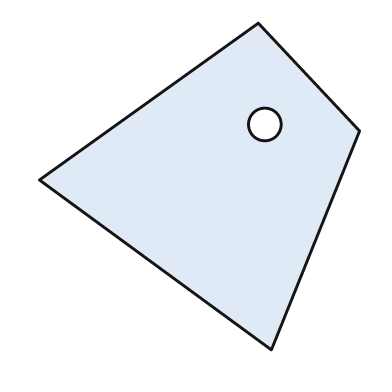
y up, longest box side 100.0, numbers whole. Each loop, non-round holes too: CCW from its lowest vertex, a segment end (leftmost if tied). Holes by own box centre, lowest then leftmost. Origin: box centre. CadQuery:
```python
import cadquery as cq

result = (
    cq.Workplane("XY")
    .moveTo(22.0, -50.0)
    .lineTo(49.0, 17.0)
    .lineTo(18.0, 50.0)
    .lineTo(-49.0, 2.0)
    .close()
    .moveTo(20.0, 19.0)
    .circle(5.0)
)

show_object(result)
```